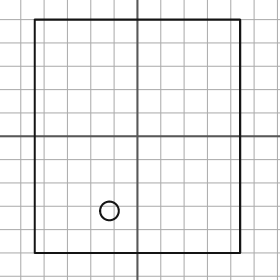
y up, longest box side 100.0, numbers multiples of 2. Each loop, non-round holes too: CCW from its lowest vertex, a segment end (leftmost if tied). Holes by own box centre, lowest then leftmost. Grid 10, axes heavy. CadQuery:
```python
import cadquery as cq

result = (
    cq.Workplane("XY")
    .moveTo(-44.0, -50.0)
    .lineTo(44.0, -50.0)
    .lineTo(44.0, 50.0)
    .lineTo(-44.0, 50.0)
    .close()
    .moveTo(-12.0, -32.0)
    .circle(4.0)
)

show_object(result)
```